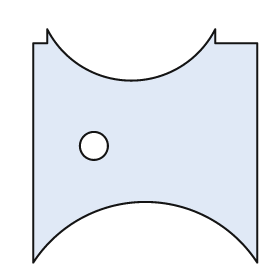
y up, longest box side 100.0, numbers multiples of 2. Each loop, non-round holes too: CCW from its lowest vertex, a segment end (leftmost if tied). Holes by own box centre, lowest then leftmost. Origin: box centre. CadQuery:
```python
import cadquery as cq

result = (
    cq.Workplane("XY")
    .moveTo(-48.0, -50.0)
    .threePointArc((0.0, -24.0), (48.0, -50.0))
    .lineTo(48.0, 44.0)
    .lineTo(30.0, 44.0)
    .lineTo(30.0, 50.0)
    .threePointArc((-6.0, 28.0), (-42.0, 50.0))
    .lineTo(-42.0, 44.0)
    .lineTo(-48.0, 44.0)
    .close()
    .moveTo(-22.0, 0.0)
    .circle(6.0)
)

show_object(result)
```